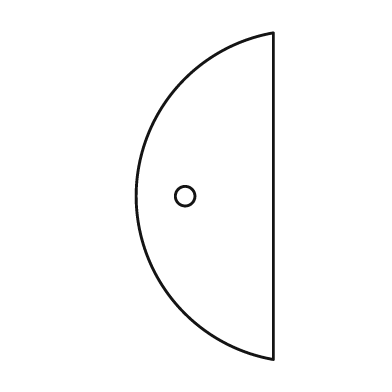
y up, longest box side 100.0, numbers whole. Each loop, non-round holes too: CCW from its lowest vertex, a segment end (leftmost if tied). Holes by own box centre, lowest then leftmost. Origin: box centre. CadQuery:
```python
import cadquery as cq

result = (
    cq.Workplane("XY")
    .moveTo(21.0, -50.0)
    .lineTo(21.0, 50.0)
    .threePointArc((-21.0, 0.0), (21.0, -50.0))
    .close()
    .moveTo(-6.0, 0.0)
    .circle(3.0)
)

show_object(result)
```